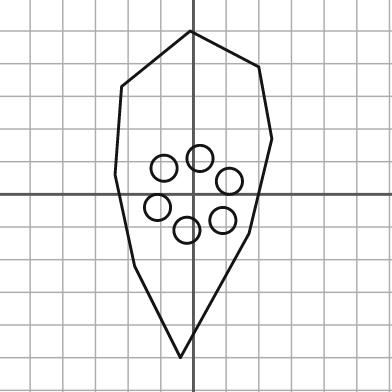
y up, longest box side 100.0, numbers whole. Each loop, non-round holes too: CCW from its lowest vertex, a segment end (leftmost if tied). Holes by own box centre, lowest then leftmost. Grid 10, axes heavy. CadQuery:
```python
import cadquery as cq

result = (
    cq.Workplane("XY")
    .moveTo(-4.0, -50.0)
    .lineTo(17.0, -12.0)
    .lineTo(24.0, 17.0)
    .lineTo(20.0, 39.0)
    .lineTo(-1.0, 50.0)
    .lineTo(-22.0, 33.0)
    .lineTo(-24.0, 6.0)
    .lineTo(-18.0, -22.0)
    .close()
    .moveTo(-2.0, -11.0)
    .circle(4.0)
    .moveTo(9.0, -8.0)
    .circle(4.0)
    .moveTo(-11.0, -4.0)
    .circle(4.0)
    .moveTo(11.0, 4.0)
    .circle(4.0)
    .moveTo(-9.0, 8.0)
    .circle(4.0)
    .moveTo(2.0, 11.0)
    .circle(4.0)
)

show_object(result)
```